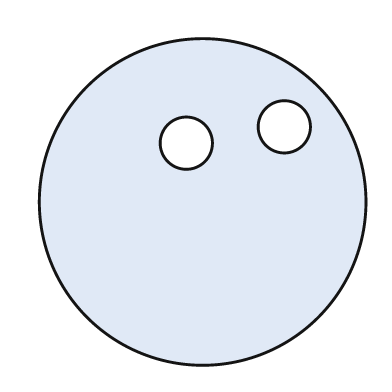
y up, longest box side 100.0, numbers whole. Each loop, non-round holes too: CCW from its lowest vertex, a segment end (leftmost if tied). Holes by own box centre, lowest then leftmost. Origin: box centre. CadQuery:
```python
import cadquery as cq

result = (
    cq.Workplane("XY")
    .moveTo(0.0, 0.0)
    .circle(50.0)
    .moveTo(-5.0, 18.0)
    .circle(8.0)
    .moveTo(25.0, 23.0)
    .circle(8.0)
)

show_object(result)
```